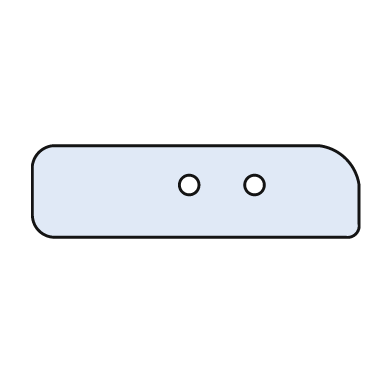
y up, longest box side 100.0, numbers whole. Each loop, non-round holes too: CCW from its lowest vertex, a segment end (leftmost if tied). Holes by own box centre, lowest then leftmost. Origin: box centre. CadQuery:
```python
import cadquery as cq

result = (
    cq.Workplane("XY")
    .moveTo(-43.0, -14.0)
    .lineTo(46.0, -14.0)
    .threePointArc((49.0, -13.0), (50.0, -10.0))
    .lineTo(50.0, 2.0)
    .threePointArc((46.0, 10.0), (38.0, 14.0))
    .lineTo(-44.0, 14.0)
    .threePointArc((-48.0, 12.0), (-50.0, 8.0))
    .lineTo(-50.0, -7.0)
    .threePointArc((-48.0, -12.0), (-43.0, -14.0))
    .close()
    .moveTo(-2.0, 2.0)
    .circle(3.0)
    .moveTo(18.0, 2.0)
    .circle(3.0)
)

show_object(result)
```